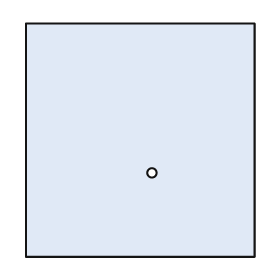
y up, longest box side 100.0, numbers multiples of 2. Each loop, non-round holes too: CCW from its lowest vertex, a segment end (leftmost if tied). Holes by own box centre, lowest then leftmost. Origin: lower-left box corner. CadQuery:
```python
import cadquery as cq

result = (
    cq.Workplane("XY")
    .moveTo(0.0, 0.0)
    .lineTo(98.0, 0.0)
    .lineTo(98.0, 100.0)
    .lineTo(0.0, 100.0)
    .close()
    .moveTo(54.0, 36.0)
    .circle(2.0)
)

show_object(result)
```